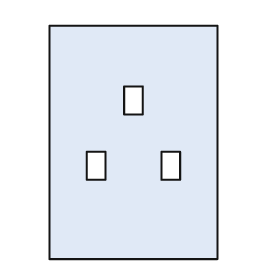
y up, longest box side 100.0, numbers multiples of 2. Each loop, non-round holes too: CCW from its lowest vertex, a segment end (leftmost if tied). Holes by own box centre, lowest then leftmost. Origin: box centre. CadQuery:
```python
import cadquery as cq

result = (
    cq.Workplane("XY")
    .moveTo(-36.0, -50.0)
    .lineTo(36.0, -50.0)
    .lineTo(36.0, 50.0)
    .lineTo(-36.0, 50.0)
    .close()
    .moveTo(-20.0, -16.0)
    .lineTo(-12.0, -16.0)
    .lineTo(-12.0, -4.0)
    .lineTo(-20.0, -4.0)
    .close()
    .moveTo(12.0, -16.0)
    .lineTo(20.0, -16.0)
    .lineTo(20.0, -4.0)
    .lineTo(12.0, -4.0)
    .close()
    .moveTo(-4.0, 12.0)
    .lineTo(4.0, 12.0)
    .lineTo(4.0, 24.0)
    .lineTo(-4.0, 24.0)
    .close()
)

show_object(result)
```